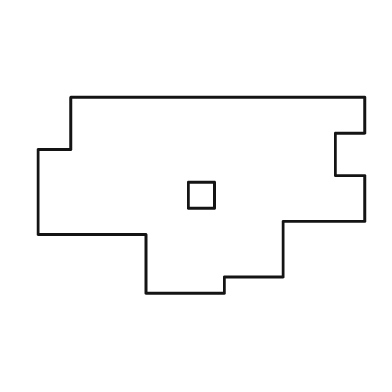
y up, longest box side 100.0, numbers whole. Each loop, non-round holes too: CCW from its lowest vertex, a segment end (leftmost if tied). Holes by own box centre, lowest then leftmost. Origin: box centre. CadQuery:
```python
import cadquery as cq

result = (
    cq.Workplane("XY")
    .moveTo(-17.0, -30.0)
    .lineTo(7.0, -30.0)
    .lineTo(7.0, -25.0)
    .lineTo(25.0, -25.0)
    .lineTo(25.0, -8.0)
    .lineTo(50.0, -8.0)
    .lineTo(50.0, 6.0)
    .lineTo(41.0, 6.0)
    .lineTo(41.0, 19.0)
    .lineTo(50.0, 19.0)
    .lineTo(50.0, 30.0)
    .lineTo(-40.0, 30.0)
    .lineTo(-40.0, 14.0)
    .lineTo(-50.0, 14.0)
    .lineTo(-50.0, -12.0)
    .lineTo(-17.0, -12.0)
    .close()
    .moveTo(-4.0, -4.0)
    .lineTo(4.0, -4.0)
    .lineTo(4.0, 4.0)
    .lineTo(-4.0, 4.0)
    .close()
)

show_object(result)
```